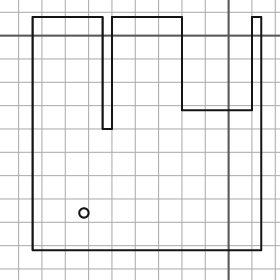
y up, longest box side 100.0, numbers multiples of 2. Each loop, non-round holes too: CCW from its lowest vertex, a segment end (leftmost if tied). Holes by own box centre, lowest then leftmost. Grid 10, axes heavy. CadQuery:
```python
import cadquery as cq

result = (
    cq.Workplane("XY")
    .moveTo(-84.0, -92.0)
    .lineTo(14.0, -92.0)
    .lineTo(14.0, 8.0)
    .lineTo(10.0, 8.0)
    .lineTo(10.0, -32.0)
    .lineTo(-20.0, -32.0)
    .lineTo(-20.0, 8.0)
    .lineTo(-50.0, 8.0)
    .lineTo(-50.0, -40.0)
    .lineTo(-54.0, -40.0)
    .lineTo(-54.0, 8.0)
    .lineTo(-84.0, 8.0)
    .close()
    .moveTo(-62.0, -76.0)
    .circle(2.0)
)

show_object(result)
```